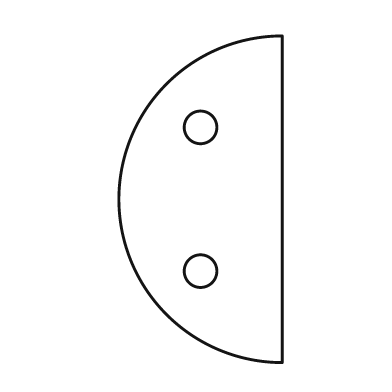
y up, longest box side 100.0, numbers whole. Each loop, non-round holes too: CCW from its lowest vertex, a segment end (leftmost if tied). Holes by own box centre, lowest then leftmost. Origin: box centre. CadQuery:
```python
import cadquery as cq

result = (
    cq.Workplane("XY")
    .moveTo(25.0, -50.0)
    .lineTo(25.0, 50.0)
    .threePointArc((-25.0, 0.0), (25.0, -50.0))
    .close()
    .moveTo(0.0, -22.0)
    .circle(5.0)
    .moveTo(0.0, 22.0)
    .circle(5.0)
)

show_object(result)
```